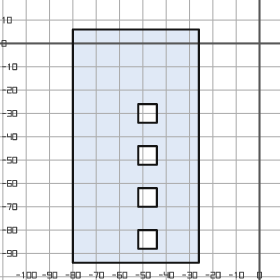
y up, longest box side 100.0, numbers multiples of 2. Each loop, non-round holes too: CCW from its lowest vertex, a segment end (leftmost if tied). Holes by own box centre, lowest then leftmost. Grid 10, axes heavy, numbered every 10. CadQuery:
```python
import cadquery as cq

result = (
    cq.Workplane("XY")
    .moveTo(-80.0, -94.0)
    .lineTo(-26.0, -94.0)
    .lineTo(-26.0, 6.0)
    .lineTo(-80.0, 6.0)
    .close()
    .moveTo(-52.0, -88.0)
    .lineTo(-44.0, -88.0)
    .lineTo(-44.0, -80.0)
    .lineTo(-52.0, -80.0)
    .close()
    .moveTo(-52.0, -70.0)
    .lineTo(-44.0, -70.0)
    .lineTo(-44.0, -62.0)
    .lineTo(-52.0, -62.0)
    .close()
    .moveTo(-52.0, -52.0)
    .lineTo(-44.0, -52.0)
    .lineTo(-44.0, -44.0)
    .lineTo(-52.0, -44.0)
    .close()
    .moveTo(-52.0, -34.0)
    .lineTo(-44.0, -34.0)
    .lineTo(-44.0, -26.0)
    .lineTo(-52.0, -26.0)
    .close()
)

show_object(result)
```